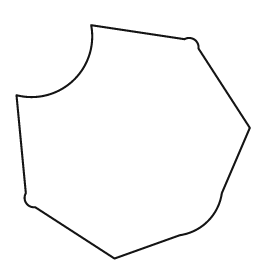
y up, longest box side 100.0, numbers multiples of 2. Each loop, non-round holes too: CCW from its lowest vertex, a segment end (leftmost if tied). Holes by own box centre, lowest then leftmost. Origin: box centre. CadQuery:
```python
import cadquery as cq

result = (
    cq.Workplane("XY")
    .moveTo(-8.0, -50.0)
    .lineTo(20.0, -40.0)
    .threePointArc((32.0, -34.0), (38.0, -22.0))
    .lineTo(50.0, 6.0)
    .lineTo(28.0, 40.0)
    .threePointArc((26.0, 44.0), (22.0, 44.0))
    .lineTo(-18.0, 50.0)
    .threePointArc((-26.0, 26.0), (-50.0, 20.0))
    .lineTo(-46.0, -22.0)
    .threePointArc((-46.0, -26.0), (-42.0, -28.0))
    .close()
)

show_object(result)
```